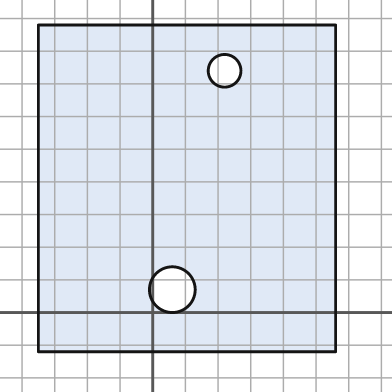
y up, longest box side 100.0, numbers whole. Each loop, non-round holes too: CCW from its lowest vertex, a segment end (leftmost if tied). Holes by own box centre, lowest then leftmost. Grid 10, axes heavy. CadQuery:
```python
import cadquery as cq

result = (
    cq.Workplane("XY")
    .moveTo(-35.0, -12.0)
    .lineTo(56.0, -12.0)
    .lineTo(56.0, 88.0)
    .lineTo(-35.0, 88.0)
    .close()
    .moveTo(6.0, 7.0)
    .circle(7.0)
    .moveTo(22.0, 74.0)
    .circle(5.0)
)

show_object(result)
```